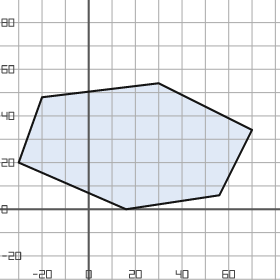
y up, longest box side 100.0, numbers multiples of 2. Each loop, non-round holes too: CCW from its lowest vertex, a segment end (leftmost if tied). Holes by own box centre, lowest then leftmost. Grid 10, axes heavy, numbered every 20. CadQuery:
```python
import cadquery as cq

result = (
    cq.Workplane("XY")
    .moveTo(16.0, 0.0)
    .lineTo(56.0, 6.0)
    .lineTo(70.0, 34.0)
    .lineTo(30.0, 54.0)
    .lineTo(-20.0, 48.0)
    .lineTo(-30.0, 20.0)
    .close()
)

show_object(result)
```